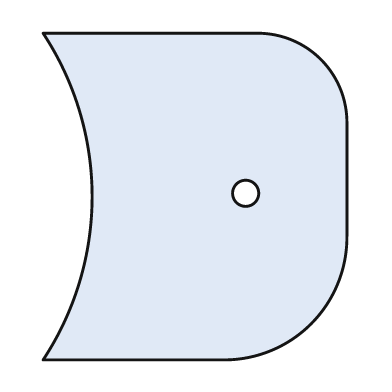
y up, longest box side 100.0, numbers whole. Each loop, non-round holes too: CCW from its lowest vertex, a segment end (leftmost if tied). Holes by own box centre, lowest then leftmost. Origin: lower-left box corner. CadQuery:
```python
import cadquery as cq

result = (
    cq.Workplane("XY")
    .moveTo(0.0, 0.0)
    .lineTo(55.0, 0.0)
    .threePointArc((82.0, 11.0), (93.0, 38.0))
    .lineTo(93.0, 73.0)
    .threePointArc((85.0, 92.0), (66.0, 100.0))
    .lineTo(0.0, 100.0)
    .threePointArc((15.0, 50.0), (0.0, 0.0))
    .close()
    .moveTo(62.0, 51.0)
    .circle(4.0)
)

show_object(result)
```